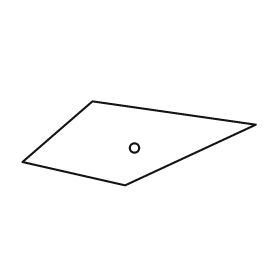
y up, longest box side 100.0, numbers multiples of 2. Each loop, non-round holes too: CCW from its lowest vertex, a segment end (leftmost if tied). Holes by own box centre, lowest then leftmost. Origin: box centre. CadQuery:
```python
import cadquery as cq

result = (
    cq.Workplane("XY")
    .moveTo(-6.0, -18.0)
    .lineTo(50.0, 8.0)
    .lineTo(-20.0, 18.0)
    .lineTo(-50.0, -8.0)
    .close()
    .moveTo(-2.0, -2.0)
    .circle(2.0)
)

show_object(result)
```